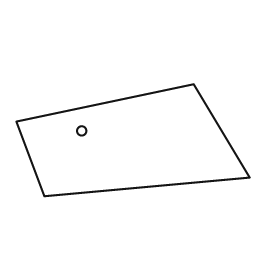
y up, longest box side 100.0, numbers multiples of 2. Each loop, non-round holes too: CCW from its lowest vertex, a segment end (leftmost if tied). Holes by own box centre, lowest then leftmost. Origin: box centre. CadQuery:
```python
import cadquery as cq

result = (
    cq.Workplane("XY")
    .moveTo(-38.0, -24.0)
    .lineTo(50.0, -16.0)
    .lineTo(26.0, 24.0)
    .lineTo(-50.0, 8.0)
    .close()
    .moveTo(-22.0, 4.0)
    .circle(2.0)
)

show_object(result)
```